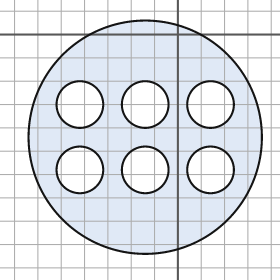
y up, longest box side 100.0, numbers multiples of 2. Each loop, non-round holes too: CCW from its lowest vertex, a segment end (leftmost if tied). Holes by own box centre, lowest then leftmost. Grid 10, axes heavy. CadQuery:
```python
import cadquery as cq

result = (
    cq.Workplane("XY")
    .moveTo(-14.0, -44.0)
    .circle(50.0)
    .moveTo(-42.0, -58.0)
    .circle(10.0)
    .moveTo(-14.0, -58.0)
    .circle(10.0)
    .moveTo(14.0, -58.0)
    .circle(10.0)
    .moveTo(-42.0, -30.0)
    .circle(10.0)
    .moveTo(-14.0, -30.0)
    .circle(10.0)
    .moveTo(14.0, -30.0)
    .circle(10.0)
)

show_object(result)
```